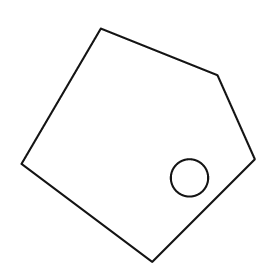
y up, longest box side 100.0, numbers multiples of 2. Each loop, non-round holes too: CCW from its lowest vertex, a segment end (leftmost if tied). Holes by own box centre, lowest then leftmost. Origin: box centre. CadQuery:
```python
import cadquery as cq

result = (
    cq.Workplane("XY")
    .moveTo(6.0, -50.0)
    .lineTo(50.0, -6.0)
    .lineTo(34.0, 30.0)
    .lineTo(-16.0, 50.0)
    .lineTo(-50.0, -8.0)
    .close()
    .moveTo(22.0, -14.0)
    .circle(8.0)
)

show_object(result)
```